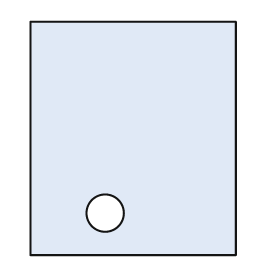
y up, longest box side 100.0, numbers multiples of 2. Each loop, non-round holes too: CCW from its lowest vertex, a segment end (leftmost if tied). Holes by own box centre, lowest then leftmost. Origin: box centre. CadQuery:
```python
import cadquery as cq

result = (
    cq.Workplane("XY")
    .moveTo(-44.0, -50.0)
    .lineTo(44.0, -50.0)
    .lineTo(44.0, 50.0)
    .lineTo(-44.0, 50.0)
    .close()
    .moveTo(-12.0, -32.0)
    .circle(8.0)
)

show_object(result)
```